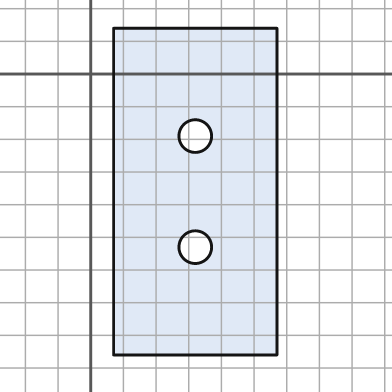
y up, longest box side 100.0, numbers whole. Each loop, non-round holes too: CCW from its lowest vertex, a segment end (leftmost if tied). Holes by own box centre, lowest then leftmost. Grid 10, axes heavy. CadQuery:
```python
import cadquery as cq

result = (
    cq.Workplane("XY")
    .moveTo(7.0, -86.0)
    .lineTo(57.0, -86.0)
    .lineTo(57.0, 14.0)
    .lineTo(7.0, 14.0)
    .close()
    .moveTo(32.0, -53.0)
    .circle(5.0)
    .moveTo(32.0, -19.0)
    .circle(5.0)
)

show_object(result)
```